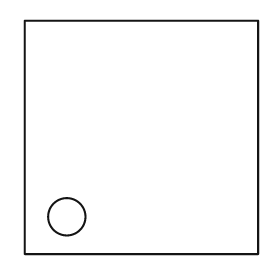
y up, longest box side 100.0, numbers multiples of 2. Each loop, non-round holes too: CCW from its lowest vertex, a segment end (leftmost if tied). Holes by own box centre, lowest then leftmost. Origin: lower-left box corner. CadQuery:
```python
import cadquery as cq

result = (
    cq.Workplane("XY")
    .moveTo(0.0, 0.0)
    .lineTo(100.0, 0.0)
    .lineTo(100.0, 100.0)
    .lineTo(0.0, 100.0)
    .close()
    .moveTo(18.0, 16.0)
    .circle(8.0)
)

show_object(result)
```